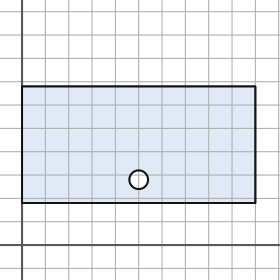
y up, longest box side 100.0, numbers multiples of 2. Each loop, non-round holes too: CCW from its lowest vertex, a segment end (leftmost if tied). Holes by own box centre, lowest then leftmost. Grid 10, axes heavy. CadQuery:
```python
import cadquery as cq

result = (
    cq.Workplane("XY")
    .moveTo(0.0, 18.0)
    .lineTo(100.0, 18.0)
    .lineTo(100.0, 68.0)
    .lineTo(0.0, 68.0)
    .close()
    .moveTo(50.0, 28.0)
    .circle(4.0)
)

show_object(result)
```